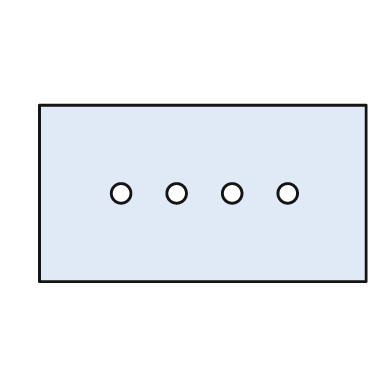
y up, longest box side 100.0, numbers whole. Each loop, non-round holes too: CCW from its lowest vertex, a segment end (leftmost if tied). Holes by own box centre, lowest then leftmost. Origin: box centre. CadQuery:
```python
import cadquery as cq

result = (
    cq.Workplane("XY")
    .moveTo(-50.0, -27.0)
    .lineTo(50.0, -27.0)
    .lineTo(50.0, 27.0)
    .lineTo(-50.0, 27.0)
    .close()
    .moveTo(-25.0, 0.0)
    .circle(3.0)
    .moveTo(-8.0, 0.0)
    .circle(3.0)
    .moveTo(9.0, 0.0)
    .circle(3.0)
    .moveTo(26.0, 0.0)
    .circle(3.0)
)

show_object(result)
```